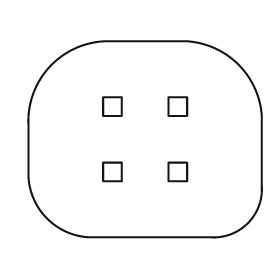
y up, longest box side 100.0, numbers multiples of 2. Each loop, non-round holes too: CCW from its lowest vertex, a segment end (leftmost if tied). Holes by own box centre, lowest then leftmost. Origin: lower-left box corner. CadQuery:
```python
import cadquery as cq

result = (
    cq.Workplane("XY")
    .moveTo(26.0, 0.0)
    .lineTo(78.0, 0.0)
    .threePointArc((94.0, 6.0), (100.0, 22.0))
    .lineTo(100.0, 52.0)
    .threePointArc((90.0, 74.0), (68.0, 84.0))
    .lineTo(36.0, 84.0)
    .threePointArc((10.0, 74.0), (0.0, 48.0))
    .lineTo(0.0, 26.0)
    .threePointArc((8.0, 8.0), (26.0, 0.0))
    .close()
    .moveTo(32.0, 24.0)
    .lineTo(40.0, 24.0)
    .lineTo(40.0, 32.0)
    .lineTo(32.0, 32.0)
    .close()
    .moveTo(60.0, 24.0)
    .lineTo(68.0, 24.0)
    .lineTo(68.0, 32.0)
    .lineTo(60.0, 32.0)
    .close()
    .moveTo(32.0, 52.0)
    .lineTo(40.0, 52.0)
    .lineTo(40.0, 60.0)
    .lineTo(32.0, 60.0)
    .close()
    .moveTo(60.0, 52.0)
    .lineTo(68.0, 52.0)
    .lineTo(68.0, 60.0)
    .lineTo(60.0, 60.0)
    .close()
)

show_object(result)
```